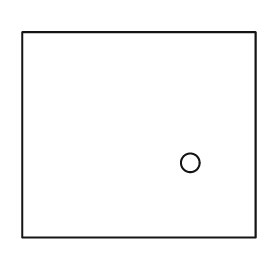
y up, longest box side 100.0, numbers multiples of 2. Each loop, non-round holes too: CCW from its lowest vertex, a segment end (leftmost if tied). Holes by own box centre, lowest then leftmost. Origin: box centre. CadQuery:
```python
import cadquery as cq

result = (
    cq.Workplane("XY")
    .moveTo(-50.0, -44.0)
    .lineTo(50.0, -44.0)
    .lineTo(50.0, 44.0)
    .lineTo(-50.0, 44.0)
    .close()
    .moveTo(22.0, -12.0)
    .circle(4.0)
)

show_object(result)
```